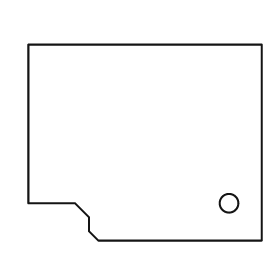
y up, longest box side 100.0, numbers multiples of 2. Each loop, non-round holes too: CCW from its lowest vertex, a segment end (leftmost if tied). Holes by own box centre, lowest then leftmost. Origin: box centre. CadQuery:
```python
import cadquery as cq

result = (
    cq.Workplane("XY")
    .moveTo(-20.0, -42.0)
    .lineTo(50.0, -42.0)
    .lineTo(50.0, 42.0)
    .lineTo(-50.0, 42.0)
    .lineTo(-50.0, -26.0)
    .lineTo(-30.0, -26.0)
    .lineTo(-24.0, -32.0)
    .lineTo(-24.0, -38.0)
    .close()
    .moveTo(36.0, -26.0)
    .circle(4.0)
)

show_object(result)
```